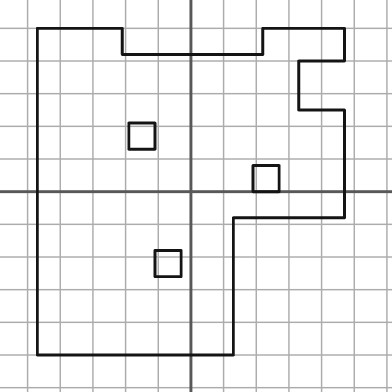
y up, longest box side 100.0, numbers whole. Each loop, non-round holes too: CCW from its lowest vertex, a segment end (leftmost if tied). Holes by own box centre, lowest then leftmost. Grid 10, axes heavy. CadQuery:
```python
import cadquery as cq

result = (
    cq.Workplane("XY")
    .moveTo(-47.0, -50.0)
    .lineTo(13.0, -50.0)
    .lineTo(13.0, -8.0)
    .lineTo(47.0, -8.0)
    .lineTo(47.0, 25.0)
    .lineTo(33.0, 25.0)
    .lineTo(33.0, 40.0)
    .lineTo(47.0, 40.0)
    .lineTo(47.0, 50.0)
    .lineTo(22.0, 50.0)
    .lineTo(22.0, 42.0)
    .lineTo(-21.0, 42.0)
    .lineTo(-21.0, 50.0)
    .lineTo(-47.0, 50.0)
    .close()
    .moveTo(-11.0, -26.0)
    .lineTo(-3.0, -26.0)
    .lineTo(-3.0, -18.0)
    .lineTo(-11.0, -18.0)
    .close()
    .moveTo(19.0, 0.0)
    .lineTo(27.0, 0.0)
    .lineTo(27.0, 8.0)
    .lineTo(19.0, 8.0)
    .close()
    .moveTo(-19.0, 13.0)
    .lineTo(-11.0, 13.0)
    .lineTo(-11.0, 21.0)
    .lineTo(-19.0, 21.0)
    .close()
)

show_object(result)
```